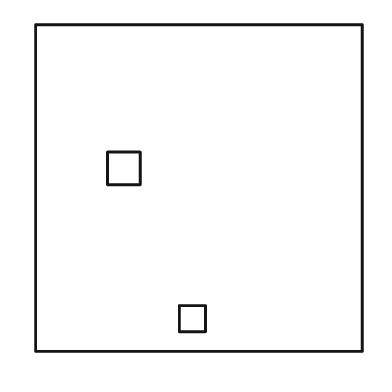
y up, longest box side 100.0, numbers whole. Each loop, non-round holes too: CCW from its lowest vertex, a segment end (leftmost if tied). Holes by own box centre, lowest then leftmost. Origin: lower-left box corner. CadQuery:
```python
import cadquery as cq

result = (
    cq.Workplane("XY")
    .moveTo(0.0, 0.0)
    .lineTo(100.0, 0.0)
    .lineTo(100.0, 100.0)
    .lineTo(0.0, 100.0)
    .close()
    .moveTo(44.0, 6.0)
    .lineTo(52.0, 6.0)
    .lineTo(52.0, 14.0)
    .lineTo(44.0, 14.0)
    .close()
    .moveTo(22.0, 51.0)
    .lineTo(32.0, 51.0)
    .lineTo(32.0, 61.0)
    .lineTo(22.0, 61.0)
    .close()
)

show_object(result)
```